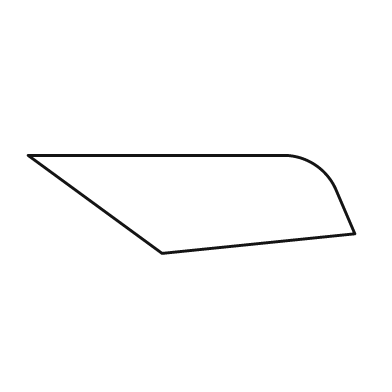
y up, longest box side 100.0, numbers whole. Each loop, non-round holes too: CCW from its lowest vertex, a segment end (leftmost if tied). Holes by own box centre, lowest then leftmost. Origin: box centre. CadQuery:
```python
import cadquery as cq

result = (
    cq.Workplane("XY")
    .moveTo(-9.0, -15.0)
    .lineTo(50.0, -9.0)
    .lineTo(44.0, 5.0)
    .threePointArc((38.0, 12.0), (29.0, 15.0))
    .lineTo(-50.0, 15.0)
    .close()
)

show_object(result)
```